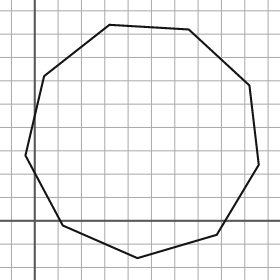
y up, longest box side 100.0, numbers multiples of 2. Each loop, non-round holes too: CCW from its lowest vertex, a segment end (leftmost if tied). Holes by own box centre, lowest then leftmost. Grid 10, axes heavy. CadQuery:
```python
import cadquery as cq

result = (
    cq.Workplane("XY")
    .moveTo(44.0, -16.0)
    .lineTo(78.0, -6.0)
    .lineTo(96.0, 24.0)
    .lineTo(92.0, 58.0)
    .lineTo(66.0, 82.0)
    .lineTo(32.0, 84.0)
    .lineTo(4.0, 62.0)
    .lineTo(-4.0, 28.0)
    .lineTo(12.0, -2.0)
    .close()
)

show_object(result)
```